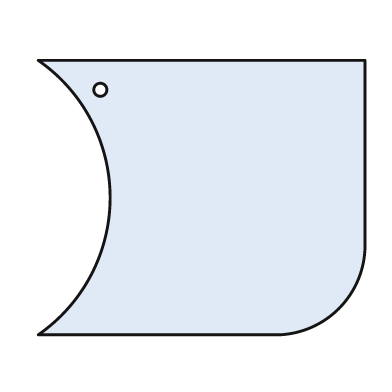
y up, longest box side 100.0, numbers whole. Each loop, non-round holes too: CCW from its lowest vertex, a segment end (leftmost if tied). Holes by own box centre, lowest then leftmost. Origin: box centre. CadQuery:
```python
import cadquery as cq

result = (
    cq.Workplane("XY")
    .moveTo(-50.0, -42.0)
    .lineTo(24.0, -42.0)
    .threePointArc((42.0, -34.0), (50.0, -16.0))
    .lineTo(50.0, 42.0)
    .lineTo(-50.0, 42.0)
    .threePointArc((-28.0, 0.0), (-50.0, -42.0))
    .close()
    .moveTo(-31.0, 33.0)
    .circle(2.0)
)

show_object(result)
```